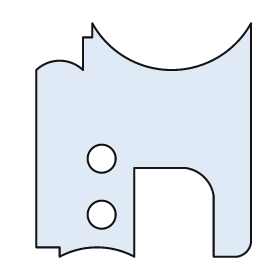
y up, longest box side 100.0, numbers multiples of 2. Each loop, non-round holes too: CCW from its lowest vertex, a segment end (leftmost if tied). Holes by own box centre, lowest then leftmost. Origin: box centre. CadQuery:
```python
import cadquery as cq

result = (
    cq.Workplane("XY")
    .moveTo(-36.0, -50.0)
    .threePointArc((-20.0, -46.0), (-4.0, -50.0))
    .lineTo(-4.0, -12.0)
    .lineTo(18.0, -12.0)
    .threePointArc((26.0, -16.0), (30.0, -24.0))
    .lineTo(30.0, -50.0)
    .lineTo(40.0, -50.0)
    .threePointArc((44.0, -48.0), (46.0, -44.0))
    .lineTo(46.0, 50.0)
    .threePointArc((12.0, 30.0), (-22.0, 50.0))
    .lineTo(-22.0, 44.0)
    .lineTo(-26.0, 44.0)
    .lineTo(-26.0, 30.0)
    .threePointArc((-36.0, 34.0), (-46.0, 30.0))
    .lineTo(-46.0, -46.0)
    .lineTo(-36.0, -46.0)
    .close()
    .moveTo(-18.0, -32.0)
    .circle(6.0)
    .moveTo(-18.0, -8.0)
    .circle(6.0)
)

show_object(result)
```